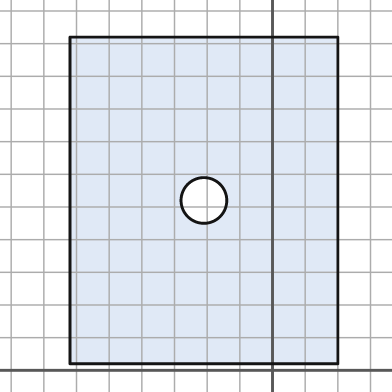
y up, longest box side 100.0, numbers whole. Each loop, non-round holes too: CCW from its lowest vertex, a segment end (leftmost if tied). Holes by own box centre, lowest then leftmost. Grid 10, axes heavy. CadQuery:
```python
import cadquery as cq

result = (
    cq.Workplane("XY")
    .moveTo(-62.0, 2.0)
    .lineTo(20.0, 2.0)
    .lineTo(20.0, 102.0)
    .lineTo(-62.0, 102.0)
    .close()
    .moveTo(-21.0, 52.0)
    .circle(7.0)
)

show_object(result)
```